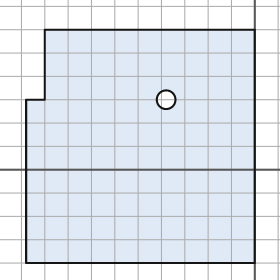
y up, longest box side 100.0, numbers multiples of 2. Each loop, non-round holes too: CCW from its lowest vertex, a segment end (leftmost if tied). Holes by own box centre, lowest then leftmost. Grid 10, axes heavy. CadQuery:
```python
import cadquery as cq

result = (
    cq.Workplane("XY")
    .moveTo(-98.0, -40.0)
    .lineTo(0.0, -40.0)
    .lineTo(0.0, 60.0)
    .lineTo(-90.0, 60.0)
    .lineTo(-90.0, 30.0)
    .lineTo(-98.0, 30.0)
    .close()
    .moveTo(-38.0, 30.0)
    .circle(4.0)
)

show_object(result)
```